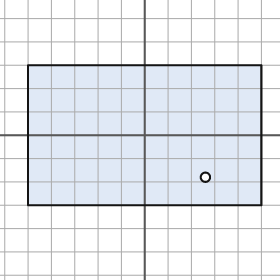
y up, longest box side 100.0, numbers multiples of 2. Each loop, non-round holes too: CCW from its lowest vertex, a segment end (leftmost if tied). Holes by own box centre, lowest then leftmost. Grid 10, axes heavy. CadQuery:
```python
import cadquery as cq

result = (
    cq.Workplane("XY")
    .moveTo(-50.0, -30.0)
    .lineTo(50.0, -30.0)
    .lineTo(50.0, 30.0)
    .lineTo(-50.0, 30.0)
    .close()
    .moveTo(26.0, -18.0)
    .circle(2.0)
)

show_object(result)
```